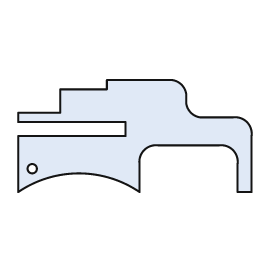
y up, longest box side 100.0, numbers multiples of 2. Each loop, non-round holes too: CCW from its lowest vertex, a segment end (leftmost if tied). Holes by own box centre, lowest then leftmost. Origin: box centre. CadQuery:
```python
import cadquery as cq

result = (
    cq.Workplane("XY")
    .moveTo(-50.0, -24.0)
    .threePointArc((-24.0, -16.0), (2.0, -24.0))
    .lineTo(2.0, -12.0)
    .threePointArc((4.0, -6.0), (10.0, -4.0))
    .lineTo(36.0, -4.0)
    .threePointArc((42.0, -6.0), (44.0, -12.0))
    .lineTo(44.0, -24.0)
    .lineTo(50.0, -24.0)
    .lineTo(50.0, 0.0)
    .threePointArc((48.0, 6.0), (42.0, 8.0))
    .lineTo(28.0, 8.0)
    .threePointArc((24.0, 10.0), (22.0, 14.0))
    .lineTo(22.0, 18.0)
    .threePointArc((20.0, 22.0), (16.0, 24.0))
    .lineTo(-12.0, 24.0)
    .lineTo(-12.0, 20.0)
    .lineTo(-32.0, 20.0)
    .lineTo(-32.0, 10.0)
    .lineTo(-50.0, 10.0)
    .lineTo(-50.0, 6.0)
    .lineTo(-4.0, 6.0)
    .lineTo(-4.0, 0.0)
    .lineTo(-50.0, 0.0)
    .close()
    .moveTo(-44.0, -14.0)
    .circle(2.0)
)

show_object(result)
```